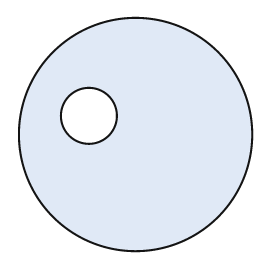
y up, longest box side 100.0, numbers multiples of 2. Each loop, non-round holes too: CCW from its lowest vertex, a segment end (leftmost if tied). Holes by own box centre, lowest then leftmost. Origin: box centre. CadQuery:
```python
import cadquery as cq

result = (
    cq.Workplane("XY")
    .moveTo(0.0, 0.0)
    .circle(50.0)
    .moveTo(-20.0, 8.0)
    .circle(12.0)
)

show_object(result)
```